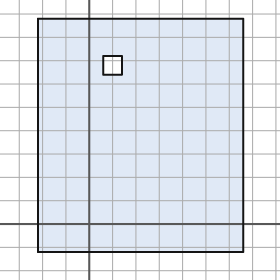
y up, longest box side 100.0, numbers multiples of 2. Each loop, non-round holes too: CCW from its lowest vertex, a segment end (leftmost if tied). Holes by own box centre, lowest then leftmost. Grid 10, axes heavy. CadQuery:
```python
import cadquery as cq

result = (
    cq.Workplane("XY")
    .moveTo(-22.0, -12.0)
    .lineTo(66.0, -12.0)
    .lineTo(66.0, 88.0)
    .lineTo(-22.0, 88.0)
    .close()
    .moveTo(6.0, 64.0)
    .lineTo(14.0, 64.0)
    .lineTo(14.0, 72.0)
    .lineTo(6.0, 72.0)
    .close()
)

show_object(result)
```